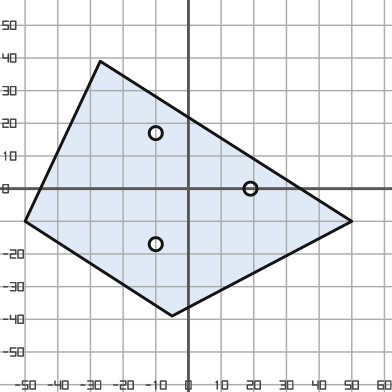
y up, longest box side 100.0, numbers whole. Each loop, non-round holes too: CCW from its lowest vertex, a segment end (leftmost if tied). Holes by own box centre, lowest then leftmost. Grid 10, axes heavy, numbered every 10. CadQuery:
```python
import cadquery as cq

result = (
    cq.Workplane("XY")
    .moveTo(-5.0, -39.0)
    .lineTo(50.0, -10.0)
    .lineTo(-27.0, 39.0)
    .lineTo(-50.0, -10.0)
    .close()
    .moveTo(-10.0, -17.0)
    .circle(2.0)
    .moveTo(19.0, 0.0)
    .circle(2.0)
    .moveTo(-10.0, 17.0)
    .circle(2.0)
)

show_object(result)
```